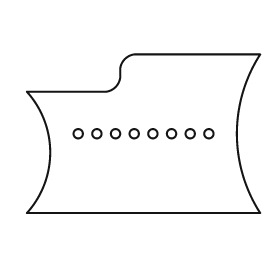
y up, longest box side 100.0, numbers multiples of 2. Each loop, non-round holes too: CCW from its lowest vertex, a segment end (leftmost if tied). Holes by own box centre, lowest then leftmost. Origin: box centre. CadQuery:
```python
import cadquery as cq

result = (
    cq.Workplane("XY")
    .moveTo(-50.0, -34.0)
    .lineTo(50.0, -34.0)
    .threePointArc((40.0, 0.0), (50.0, 34.0))
    .lineTo(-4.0, 34.0)
    .threePointArc((-8.0, 32.0), (-10.0, 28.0))
    .lineTo(-10.0, 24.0)
    .threePointArc((-12.0, 20.0), (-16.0, 18.0))
    .lineTo(-50.0, 18.0)
    .threePointArc((-40.0, -8.0), (-50.0, -34.0))
    .close()
    .moveTo(-28.0, 0.0)
    .circle(2.0)
    .moveTo(-20.0, 0.0)
    .circle(2.0)
    .moveTo(-12.0, 0.0)
    .circle(2.0)
    .moveTo(-4.0, 0.0)
    .circle(2.0)
    .moveTo(4.0, 0.0)
    .circle(2.0)
    .moveTo(12.0, 0.0)
    .circle(2.0)
    .moveTo(20.0, 0.0)
    .circle(2.0)
    .moveTo(28.0, 0.0)
    .circle(2.0)
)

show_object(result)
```